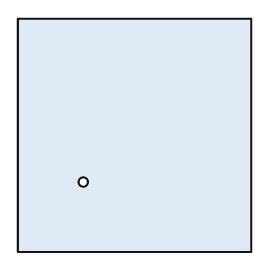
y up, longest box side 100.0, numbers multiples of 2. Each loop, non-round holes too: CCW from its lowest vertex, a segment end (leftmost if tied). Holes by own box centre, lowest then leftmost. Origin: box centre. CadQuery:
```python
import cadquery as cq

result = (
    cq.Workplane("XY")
    .moveTo(-50.0, -50.0)
    .lineTo(50.0, -50.0)
    .lineTo(50.0, 50.0)
    .lineTo(-50.0, 50.0)
    .close()
    .moveTo(-22.0, -20.0)
    .circle(2.0)
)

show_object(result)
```